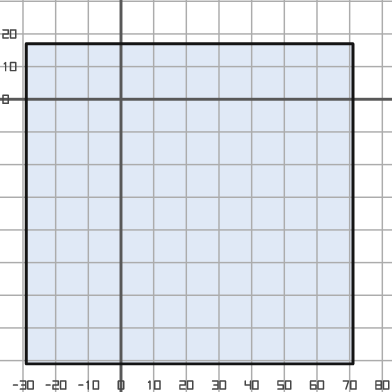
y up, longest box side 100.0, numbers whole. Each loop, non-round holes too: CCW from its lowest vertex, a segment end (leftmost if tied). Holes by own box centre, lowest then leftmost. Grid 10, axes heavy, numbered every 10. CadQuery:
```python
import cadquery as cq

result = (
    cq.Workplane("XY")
    .moveTo(-29.0, -81.0)
    .lineTo(71.0, -81.0)
    .lineTo(71.0, 17.0)
    .lineTo(-29.0, 17.0)
    .close()
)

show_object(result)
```